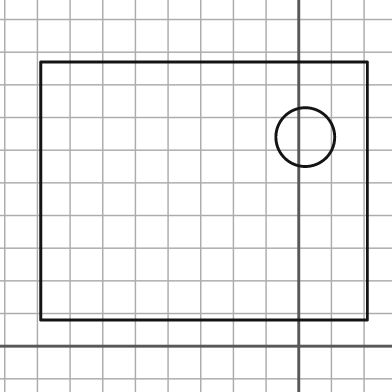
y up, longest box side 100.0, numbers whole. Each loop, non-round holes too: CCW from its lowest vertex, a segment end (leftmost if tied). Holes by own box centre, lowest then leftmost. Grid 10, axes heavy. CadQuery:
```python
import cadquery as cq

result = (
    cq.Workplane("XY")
    .moveTo(-79.0, 8.0)
    .lineTo(21.0, 8.0)
    .lineTo(21.0, 87.0)
    .lineTo(-79.0, 87.0)
    .close()
    .moveTo(2.0, 64.0)
    .circle(9.0)
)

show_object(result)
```